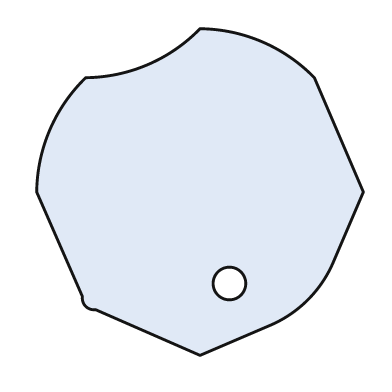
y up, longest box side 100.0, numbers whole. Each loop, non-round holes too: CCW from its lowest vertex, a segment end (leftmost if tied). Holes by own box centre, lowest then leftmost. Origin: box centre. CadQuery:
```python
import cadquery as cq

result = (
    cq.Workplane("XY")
    .moveTo(0.0, -50.0)
    .lineTo(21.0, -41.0)
    .threePointArc((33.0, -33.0), (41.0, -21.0))
    .lineTo(50.0, 0.0)
    .lineTo(35.0, 35.0)
    .threePointArc((19.0, 46.0), (0.0, 50.0))
    .threePointArc((-16.0, 39.0), (-35.0, 35.0))
    .threePointArc((-46.0, 19.0), (-50.0, 0.0))
    .lineTo(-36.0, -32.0)
    .threePointArc((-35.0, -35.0), (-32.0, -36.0))
    .close()
    .moveTo(9.0, -28.0)
    .circle(5.0)
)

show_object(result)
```